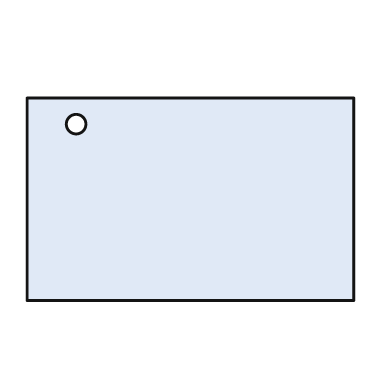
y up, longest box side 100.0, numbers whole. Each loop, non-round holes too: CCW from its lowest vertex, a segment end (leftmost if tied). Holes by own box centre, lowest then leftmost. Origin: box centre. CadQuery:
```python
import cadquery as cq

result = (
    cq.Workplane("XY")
    .moveTo(-50.0, -31.0)
    .lineTo(50.0, -31.0)
    .lineTo(50.0, 31.0)
    .lineTo(-50.0, 31.0)
    .close()
    .moveTo(-35.0, 23.0)
    .circle(3.0)
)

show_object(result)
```